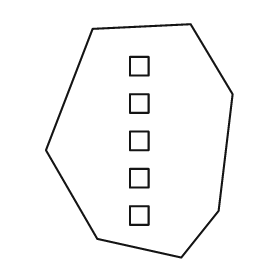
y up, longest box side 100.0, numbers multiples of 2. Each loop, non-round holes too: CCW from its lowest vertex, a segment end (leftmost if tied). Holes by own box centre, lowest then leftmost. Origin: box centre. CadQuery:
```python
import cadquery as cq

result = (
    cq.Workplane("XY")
    .moveTo(18.0, -50.0)
    .lineTo(34.0, -30.0)
    .lineTo(40.0, 20.0)
    .lineTo(22.0, 50.0)
    .lineTo(-20.0, 48.0)
    .lineTo(-40.0, -4.0)
    .lineTo(-18.0, -42.0)
    .close()
    .moveTo(-4.0, -36.0)
    .lineTo(4.0, -36.0)
    .lineTo(4.0, -28.0)
    .lineTo(-4.0, -28.0)
    .close()
    .moveTo(-4.0, -20.0)
    .lineTo(4.0, -20.0)
    .lineTo(4.0, -12.0)
    .lineTo(-4.0, -12.0)
    .close()
    .moveTo(-4.0, -4.0)
    .lineTo(4.0, -4.0)
    .lineTo(4.0, 4.0)
    .lineTo(-4.0, 4.0)
    .close()
    .moveTo(-4.0, 12.0)
    .lineTo(4.0, 12.0)
    .lineTo(4.0, 20.0)
    .lineTo(-4.0, 20.0)
    .close()
    .moveTo(-4.0, 28.0)
    .lineTo(4.0, 28.0)
    .lineTo(4.0, 36.0)
    .lineTo(-4.0, 36.0)
    .close()
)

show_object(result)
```